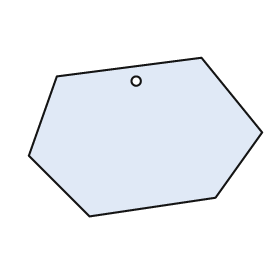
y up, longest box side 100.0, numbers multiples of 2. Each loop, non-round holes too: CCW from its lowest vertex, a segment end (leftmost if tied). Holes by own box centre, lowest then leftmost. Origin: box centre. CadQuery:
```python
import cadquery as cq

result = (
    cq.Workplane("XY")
    .moveTo(-24.0, -34.0)
    .lineTo(30.0, -26.0)
    .lineTo(50.0, 2.0)
    .lineTo(24.0, 34.0)
    .lineTo(-38.0, 26.0)
    .lineTo(-50.0, -8.0)
    .close()
    .moveTo(-4.0, 24.0)
    .circle(2.0)
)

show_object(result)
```